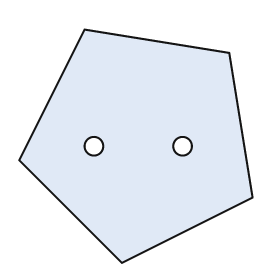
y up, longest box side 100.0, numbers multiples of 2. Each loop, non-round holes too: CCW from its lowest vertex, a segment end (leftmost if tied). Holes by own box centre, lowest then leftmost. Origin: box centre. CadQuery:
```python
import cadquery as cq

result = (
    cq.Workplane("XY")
    .moveTo(-6.0, -50.0)
    .lineTo(50.0, -22.0)
    .lineTo(40.0, 40.0)
    .lineTo(-22.0, 50.0)
    .lineTo(-50.0, -6.0)
    .close()
    .moveTo(-18.0, 0.0)
    .circle(4.0)
    .moveTo(20.0, 0.0)
    .circle(4.0)
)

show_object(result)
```